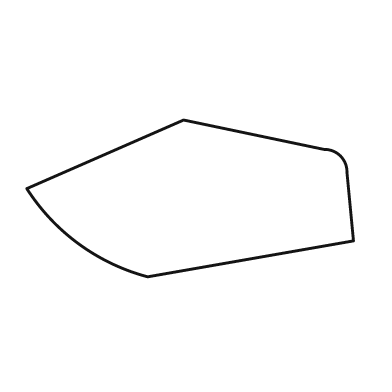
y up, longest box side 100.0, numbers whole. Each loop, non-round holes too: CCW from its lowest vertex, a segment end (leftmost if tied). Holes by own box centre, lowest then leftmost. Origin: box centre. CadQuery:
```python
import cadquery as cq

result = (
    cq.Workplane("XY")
    .moveTo(-13.0, -24.0)
    .lineTo(50.0, -13.0)
    .lineTo(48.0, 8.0)
    .threePointArc((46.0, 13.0), (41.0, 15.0))
    .lineTo(-2.0, 24.0)
    .lineTo(-50.0, 3.0)
    .threePointArc((-34.0, -14.0), (-13.0, -24.0))
    .close()
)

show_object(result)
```